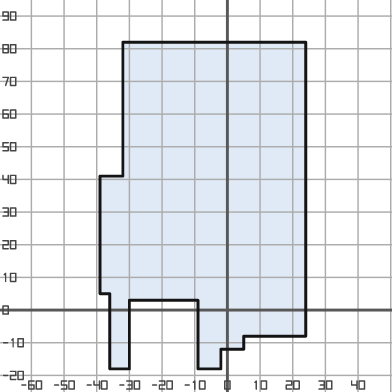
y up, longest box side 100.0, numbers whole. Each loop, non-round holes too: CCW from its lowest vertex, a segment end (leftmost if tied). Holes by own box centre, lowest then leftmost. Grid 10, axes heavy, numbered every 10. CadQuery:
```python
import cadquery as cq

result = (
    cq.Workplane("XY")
    .moveTo(-36.0, -18.0)
    .lineTo(-30.0, -18.0)
    .lineTo(-30.0, 3.0)
    .lineTo(-9.0, 3.0)
    .lineTo(-9.0, -18.0)
    .lineTo(-2.0, -18.0)
    .lineTo(-2.0, -12.0)
    .lineTo(5.0, -12.0)
    .lineTo(5.0, -8.0)
    .lineTo(24.0, -8.0)
    .lineTo(24.0, 82.0)
    .lineTo(-32.0, 82.0)
    .lineTo(-32.0, 41.0)
    .lineTo(-39.0, 41.0)
    .lineTo(-39.0, 5.0)
    .lineTo(-36.0, 5.0)
    .close()
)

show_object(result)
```